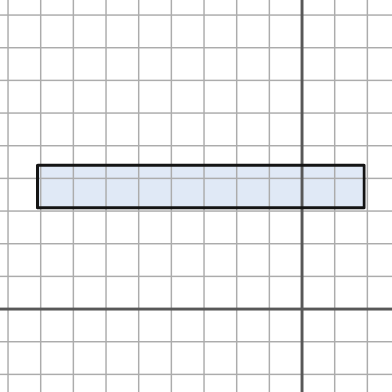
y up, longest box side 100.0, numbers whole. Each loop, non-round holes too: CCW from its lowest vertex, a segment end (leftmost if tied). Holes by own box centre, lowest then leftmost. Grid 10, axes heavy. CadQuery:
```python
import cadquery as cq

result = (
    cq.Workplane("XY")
    .moveTo(-81.0, 31.0)
    .lineTo(19.0, 31.0)
    .lineTo(19.0, 44.0)
    .lineTo(-81.0, 44.0)
    .close()
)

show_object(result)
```